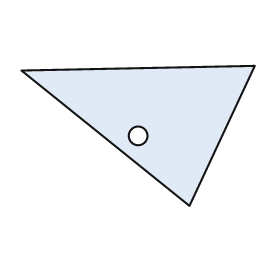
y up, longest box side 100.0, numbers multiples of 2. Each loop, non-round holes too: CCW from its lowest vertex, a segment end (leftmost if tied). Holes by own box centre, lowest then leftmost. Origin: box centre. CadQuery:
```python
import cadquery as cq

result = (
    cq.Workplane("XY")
    .moveTo(22.0, -30.0)
    .lineTo(50.0, 30.0)
    .lineTo(-50.0, 28.0)
    .close()
    .moveTo(0.0, 0.0)
    .circle(4.0)
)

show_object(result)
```